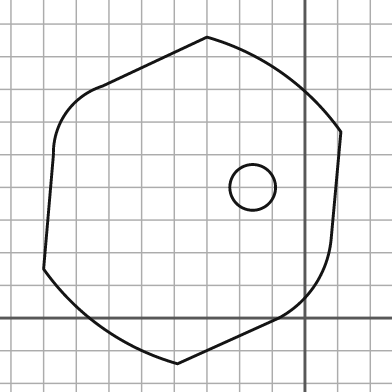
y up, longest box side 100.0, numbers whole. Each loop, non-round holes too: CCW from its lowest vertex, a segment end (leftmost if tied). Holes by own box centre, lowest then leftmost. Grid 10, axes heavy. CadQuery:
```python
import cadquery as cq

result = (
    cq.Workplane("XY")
    .moveTo(-39.0, -14.0)
    .lineTo(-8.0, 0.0)
    .threePointArc((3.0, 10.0), (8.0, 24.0))
    .lineTo(11.0, 57.0)
    .threePointArc((-7.0, 75.0), (-30.0, 86.0))
    .lineTo(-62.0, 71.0)
    .threePointArc((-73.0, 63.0), (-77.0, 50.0))
    .lineTo(-80.0, 15.0)
    .threePointArc((-62.0, -3.0), (-39.0, -14.0))
    .close()
    .moveTo(-16.0, 40.0)
    .circle(7.0)
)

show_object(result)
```